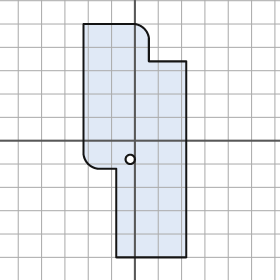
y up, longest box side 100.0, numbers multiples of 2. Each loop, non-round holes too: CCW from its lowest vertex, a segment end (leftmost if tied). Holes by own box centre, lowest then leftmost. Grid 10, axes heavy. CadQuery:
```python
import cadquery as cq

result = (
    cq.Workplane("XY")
    .moveTo(-8.0, -50.0)
    .lineTo(22.0, -50.0)
    .lineTo(22.0, 34.0)
    .lineTo(6.0, 34.0)
    .lineTo(6.0, 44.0)
    .threePointArc((4.0, 48.0), (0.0, 50.0))
    .lineTo(-22.0, 50.0)
    .lineTo(-22.0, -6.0)
    .threePointArc((-20.0, -10.0), (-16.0, -12.0))
    .lineTo(-8.0, -12.0)
    .close()
    .moveTo(-2.0, -8.0)
    .circle(2.0)
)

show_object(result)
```